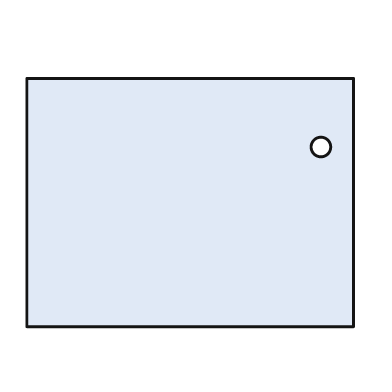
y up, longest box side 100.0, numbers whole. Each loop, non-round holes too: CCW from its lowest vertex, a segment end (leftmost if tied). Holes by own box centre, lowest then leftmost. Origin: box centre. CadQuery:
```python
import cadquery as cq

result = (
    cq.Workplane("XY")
    .moveTo(-50.0, -38.0)
    .lineTo(50.0, -38.0)
    .lineTo(50.0, 38.0)
    .lineTo(-50.0, 38.0)
    .close()
    .moveTo(40.0, 17.0)
    .circle(3.0)
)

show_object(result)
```